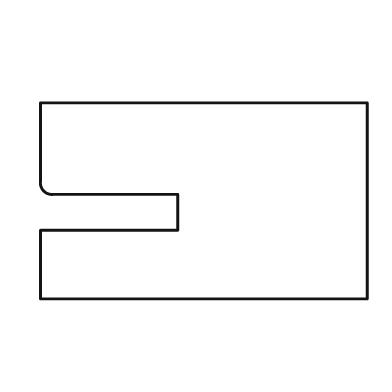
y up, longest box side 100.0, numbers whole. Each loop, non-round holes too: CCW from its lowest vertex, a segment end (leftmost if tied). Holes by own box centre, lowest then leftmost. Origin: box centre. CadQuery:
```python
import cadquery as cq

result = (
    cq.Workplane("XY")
    .moveTo(-50.0, -30.0)
    .lineTo(50.0, -30.0)
    .lineTo(50.0, 30.0)
    .lineTo(-50.0, 30.0)
    .lineTo(-50.0, 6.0)
    .threePointArc((-49.0, 3.0), (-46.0, 2.0))
    .lineTo(-8.0, 2.0)
    .lineTo(-8.0, -9.0)
    .lineTo(-50.0, -9.0)
    .close()
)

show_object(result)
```